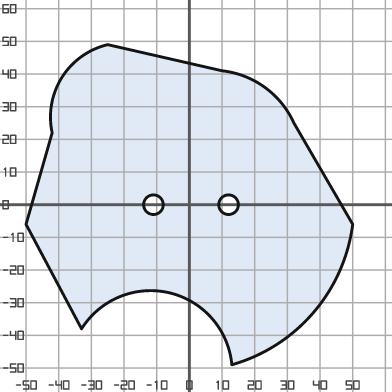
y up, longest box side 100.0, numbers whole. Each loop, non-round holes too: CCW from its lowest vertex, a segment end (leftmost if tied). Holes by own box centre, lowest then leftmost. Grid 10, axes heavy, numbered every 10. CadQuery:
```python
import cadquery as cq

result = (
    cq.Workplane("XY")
    .moveTo(13.0, -49.0)
    .threePointArc((38.0, -33.0), (50.0, -6.0))
    .lineTo(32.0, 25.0)
    .threePointArc((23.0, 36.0), (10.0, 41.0))
    .lineTo(-25.0, 49.0)
    .threePointArc((-39.0, 39.0), (-42.0, 22.0))
    .lineTo(-50.0, -6.0)
    .lineTo(-33.0, -38.0)
    .threePointArc((-6.0, -27.0), (13.0, -49.0))
    .close()
    .moveTo(-11.0, 0.0)
    .circle(3.0)
    .moveTo(12.0, 0.0)
    .circle(3.0)
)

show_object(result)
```